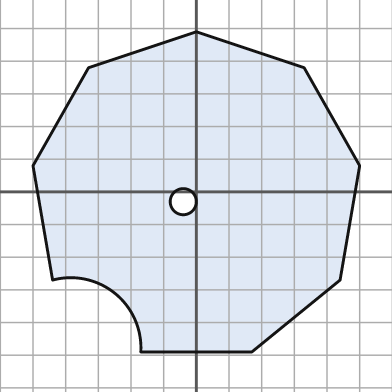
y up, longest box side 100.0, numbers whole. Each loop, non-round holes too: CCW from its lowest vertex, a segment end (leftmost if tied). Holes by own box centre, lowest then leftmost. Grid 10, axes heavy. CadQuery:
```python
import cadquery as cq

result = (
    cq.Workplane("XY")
    .moveTo(-17.0, -49.0)
    .lineTo(17.0, -49.0)
    .lineTo(44.0, -27.0)
    .lineTo(50.0, 8.0)
    .lineTo(33.0, 38.0)
    .lineTo(0.0, 49.0)
    .lineTo(-33.0, 38.0)
    .lineTo(-50.0, 8.0)
    .lineTo(-44.0, -27.0)
    .threePointArc((-25.0, -31.0), (-17.0, -49.0))
    .close()
    .moveTo(-4.0, -3.0)
    .circle(4.0)
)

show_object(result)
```